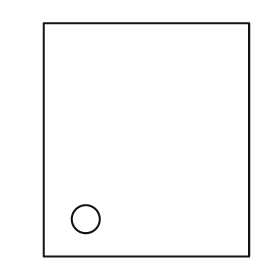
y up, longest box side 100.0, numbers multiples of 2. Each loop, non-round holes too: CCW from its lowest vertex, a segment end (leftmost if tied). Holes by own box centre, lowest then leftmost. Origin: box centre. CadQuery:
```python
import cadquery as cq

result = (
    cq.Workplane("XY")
    .moveTo(-44.0, -50.0)
    .lineTo(44.0, -50.0)
    .lineTo(44.0, 50.0)
    .lineTo(-44.0, 50.0)
    .close()
    .moveTo(-26.0, -34.0)
    .circle(6.0)
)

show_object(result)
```